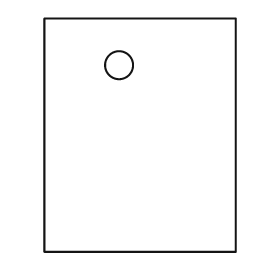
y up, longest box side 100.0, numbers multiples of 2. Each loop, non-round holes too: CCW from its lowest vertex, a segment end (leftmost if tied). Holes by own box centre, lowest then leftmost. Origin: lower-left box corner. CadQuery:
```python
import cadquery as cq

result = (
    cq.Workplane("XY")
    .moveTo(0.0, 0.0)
    .lineTo(82.0, 0.0)
    .lineTo(82.0, 100.0)
    .lineTo(0.0, 100.0)
    .close()
    .moveTo(32.0, 80.0)
    .circle(6.0)
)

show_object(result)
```